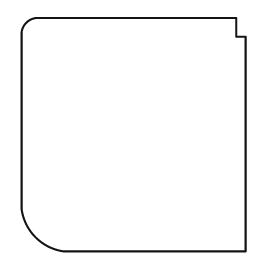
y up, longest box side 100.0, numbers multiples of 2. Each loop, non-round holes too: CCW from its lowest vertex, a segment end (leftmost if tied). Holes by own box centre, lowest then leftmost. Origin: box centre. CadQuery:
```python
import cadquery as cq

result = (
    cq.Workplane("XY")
    .moveTo(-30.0, -50.0)
    .lineTo(48.0, -50.0)
    .lineTo(48.0, 42.0)
    .lineTo(44.0, 42.0)
    .lineTo(44.0, 50.0)
    .lineTo(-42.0, 50.0)
    .threePointArc((-46.0, 48.0), (-48.0, 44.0))
    .lineTo(-48.0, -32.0)
    .threePointArc((-42.0, -44.0), (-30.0, -50.0))
    .close()
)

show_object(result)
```